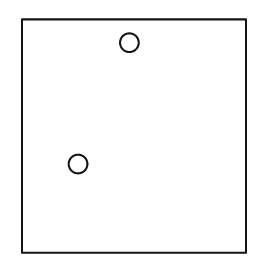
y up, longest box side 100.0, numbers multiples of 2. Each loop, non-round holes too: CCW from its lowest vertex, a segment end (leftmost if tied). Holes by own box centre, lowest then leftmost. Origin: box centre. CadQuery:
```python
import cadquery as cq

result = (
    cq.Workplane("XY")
    .moveTo(-48.0, -50.0)
    .lineTo(48.0, -50.0)
    .lineTo(48.0, 50.0)
    .lineTo(-48.0, 50.0)
    .close()
    .moveTo(-24.0, -12.0)
    .circle(4.0)
    .moveTo(-2.0, 40.0)
    .circle(4.0)
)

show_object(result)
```